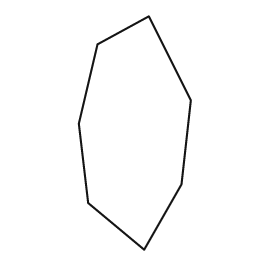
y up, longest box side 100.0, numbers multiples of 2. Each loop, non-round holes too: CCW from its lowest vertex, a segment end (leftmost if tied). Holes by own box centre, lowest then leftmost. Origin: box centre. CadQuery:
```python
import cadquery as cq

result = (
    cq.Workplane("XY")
    .moveTo(4.0, -50.0)
    .lineTo(20.0, -22.0)
    .lineTo(24.0, 14.0)
    .lineTo(6.0, 50.0)
    .lineTo(-16.0, 38.0)
    .lineTo(-24.0, 4.0)
    .lineTo(-20.0, -30.0)
    .close()
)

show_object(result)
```